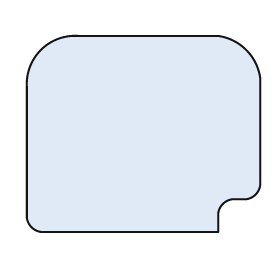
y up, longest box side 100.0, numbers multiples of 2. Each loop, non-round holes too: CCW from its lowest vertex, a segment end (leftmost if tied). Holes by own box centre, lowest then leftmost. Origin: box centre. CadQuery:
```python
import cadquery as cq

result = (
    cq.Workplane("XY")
    .moveTo(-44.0, -42.0)
    .lineTo(32.0, -42.0)
    .lineTo(32.0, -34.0)
    .threePointArc((34.0, -30.0), (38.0, -28.0))
    .lineTo(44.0, -28.0)
    .threePointArc((48.0, -26.0), (50.0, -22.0))
    .lineTo(50.0, 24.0)
    .threePointArc((44.0, 36.0), (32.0, 42.0))
    .lineTo(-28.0, 42.0)
    .threePointArc((-44.0, 36.0), (-50.0, 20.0))
    .lineTo(-50.0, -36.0)
    .threePointArc((-48.0, -40.0), (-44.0, -42.0))
    .close()
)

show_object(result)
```